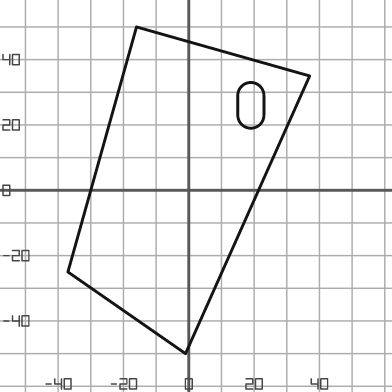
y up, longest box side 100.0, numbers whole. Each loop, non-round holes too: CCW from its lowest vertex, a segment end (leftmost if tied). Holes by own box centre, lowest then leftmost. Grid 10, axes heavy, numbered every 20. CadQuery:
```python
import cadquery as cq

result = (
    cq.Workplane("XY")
    .moveTo(-1.0, -50.0)
    .lineTo(37.0, 35.0)
    .lineTo(-16.0, 50.0)
    .lineTo(-37.0, -25.0)
    .close()
    .moveTo(15.0, 23.0)
    .threePointArc((19.0, 19.0), (23.0, 23.0))
    .lineTo(23.0, 29.0)
    .threePointArc((19.0, 33.0), (15.0, 29.0))
    .close()
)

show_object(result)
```